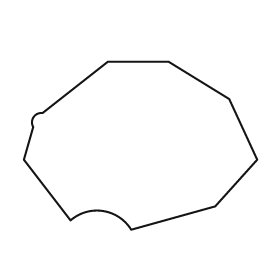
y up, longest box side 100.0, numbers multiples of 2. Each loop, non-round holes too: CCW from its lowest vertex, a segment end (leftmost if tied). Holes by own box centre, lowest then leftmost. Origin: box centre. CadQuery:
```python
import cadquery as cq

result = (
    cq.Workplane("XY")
    .moveTo(-4.0, -36.0)
    .lineTo(32.0, -26.0)
    .lineTo(50.0, -6.0)
    .lineTo(38.0, 20.0)
    .lineTo(12.0, 36.0)
    .lineTo(-14.0, 36.0)
    .lineTo(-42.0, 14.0)
    .threePointArc((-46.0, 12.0), (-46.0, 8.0))
    .lineTo(-50.0, -6.0)
    .lineTo(-30.0, -32.0)
    .threePointArc((-16.0, -28.0), (-4.0, -36.0))
    .close()
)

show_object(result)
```